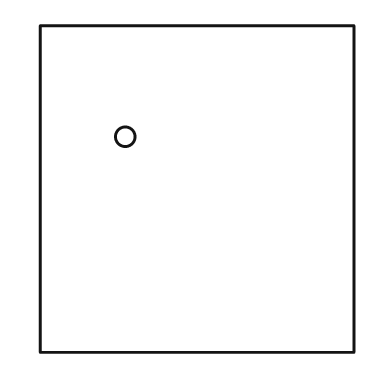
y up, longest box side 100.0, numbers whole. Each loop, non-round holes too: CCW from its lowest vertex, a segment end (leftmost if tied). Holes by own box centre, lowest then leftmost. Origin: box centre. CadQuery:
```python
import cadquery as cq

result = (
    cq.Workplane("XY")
    .moveTo(-48.0, -50.0)
    .lineTo(48.0, -50.0)
    .lineTo(48.0, 50.0)
    .lineTo(-48.0, 50.0)
    .close()
    .moveTo(-22.0, 16.0)
    .circle(3.0)
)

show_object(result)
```